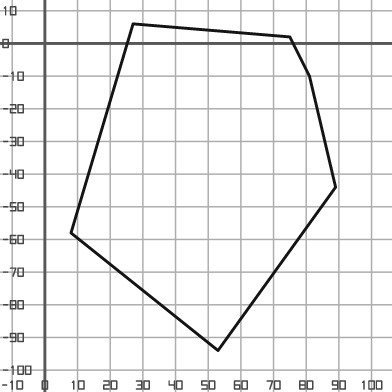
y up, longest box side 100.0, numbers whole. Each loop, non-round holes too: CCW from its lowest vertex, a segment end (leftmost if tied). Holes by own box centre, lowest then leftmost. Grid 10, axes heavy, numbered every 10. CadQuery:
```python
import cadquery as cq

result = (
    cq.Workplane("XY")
    .moveTo(53.0, -94.0)
    .lineTo(89.0, -44.0)
    .lineTo(81.0, -10.0)
    .lineTo(75.0, 2.0)
    .lineTo(27.0, 6.0)
    .lineTo(8.0, -58.0)
    .close()
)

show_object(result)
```